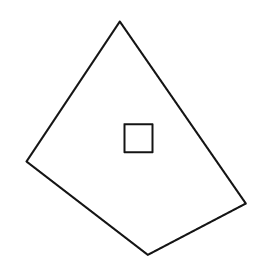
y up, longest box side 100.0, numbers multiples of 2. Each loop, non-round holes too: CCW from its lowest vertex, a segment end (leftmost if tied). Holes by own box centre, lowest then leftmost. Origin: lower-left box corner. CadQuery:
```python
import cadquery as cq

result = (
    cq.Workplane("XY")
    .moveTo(52.0, 0.0)
    .lineTo(94.0, 22.0)
    .lineTo(40.0, 100.0)
    .lineTo(0.0, 40.0)
    .close()
    .moveTo(42.0, 44.0)
    .lineTo(54.0, 44.0)
    .lineTo(54.0, 56.0)
    .lineTo(42.0, 56.0)
    .close()
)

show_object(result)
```